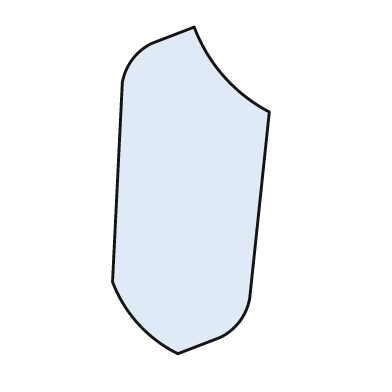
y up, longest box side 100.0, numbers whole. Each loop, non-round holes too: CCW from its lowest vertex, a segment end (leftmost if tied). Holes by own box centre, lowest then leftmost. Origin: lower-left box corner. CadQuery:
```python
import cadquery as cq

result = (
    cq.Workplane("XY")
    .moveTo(20.0, 0.0)
    .lineTo(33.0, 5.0)
    .threePointArc((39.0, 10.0), (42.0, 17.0))
    .lineTo(48.0, 74.0)
    .threePointArc((34.0, 85.0), (25.0, 100.0))
    .lineTo(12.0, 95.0)
    .threePointArc((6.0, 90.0), (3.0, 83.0))
    .lineTo(0.0, 22.0)
    .threePointArc((8.0, 9.0), (20.0, 0.0))
    .close()
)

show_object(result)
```